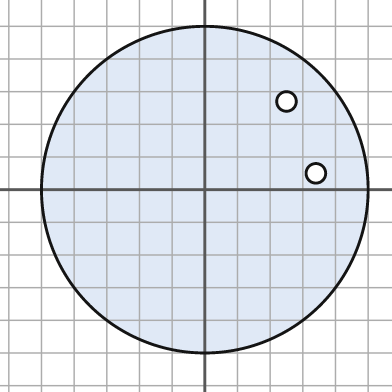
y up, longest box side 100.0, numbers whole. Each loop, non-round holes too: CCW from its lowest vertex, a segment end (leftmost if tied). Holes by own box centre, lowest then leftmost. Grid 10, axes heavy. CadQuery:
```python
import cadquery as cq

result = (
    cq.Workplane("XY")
    .moveTo(0.0, 0.0)
    .circle(50.0)
    .moveTo(34.0, 5.0)
    .circle(3.0)
    .moveTo(25.0, 27.0)
    .circle(3.0)
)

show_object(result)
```